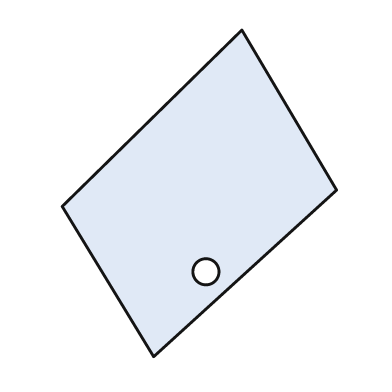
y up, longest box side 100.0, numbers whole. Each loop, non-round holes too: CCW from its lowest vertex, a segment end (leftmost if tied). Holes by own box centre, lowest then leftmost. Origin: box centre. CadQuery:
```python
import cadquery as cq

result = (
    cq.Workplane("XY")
    .moveTo(-14.0, -50.0)
    .lineTo(42.0, 1.0)
    .lineTo(13.0, 50.0)
    .lineTo(-42.0, -4.0)
    .close()
    .moveTo(2.0, -24.0)
    .circle(4.0)
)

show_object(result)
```